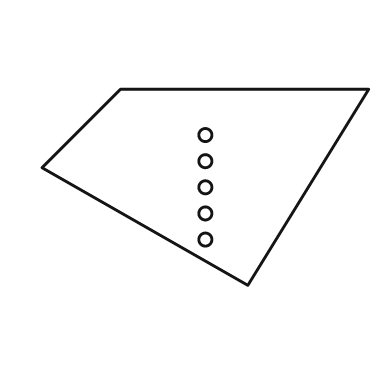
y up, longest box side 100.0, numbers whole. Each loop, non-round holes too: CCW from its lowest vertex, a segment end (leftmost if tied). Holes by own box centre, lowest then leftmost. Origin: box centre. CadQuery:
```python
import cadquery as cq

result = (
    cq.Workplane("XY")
    .moveTo(13.0, -30.0)
    .lineTo(50.0, 30.0)
    .lineTo(-26.0, 30.0)
    .lineTo(-50.0, 6.0)
    .close()
    .moveTo(0.0, -16.0)
    .circle(2.0)
    .moveTo(0.0, -8.0)
    .circle(2.0)
    .moveTo(0.0, 0.0)
    .circle(2.0)
    .moveTo(0.0, 8.0)
    .circle(2.0)
    .moveTo(0.0, 16.0)
    .circle(2.0)
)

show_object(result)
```